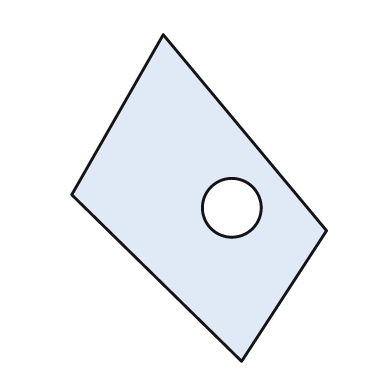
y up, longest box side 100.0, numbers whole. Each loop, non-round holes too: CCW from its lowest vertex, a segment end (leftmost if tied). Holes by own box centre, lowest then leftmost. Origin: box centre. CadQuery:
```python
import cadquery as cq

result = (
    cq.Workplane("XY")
    .moveTo(13.0, -50.0)
    .lineTo(39.0, -10.0)
    .lineTo(-11.0, 50.0)
    .lineTo(-39.0, 1.0)
    .close()
    .moveTo(10.0, -3.0)
    .circle(9.0)
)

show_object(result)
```